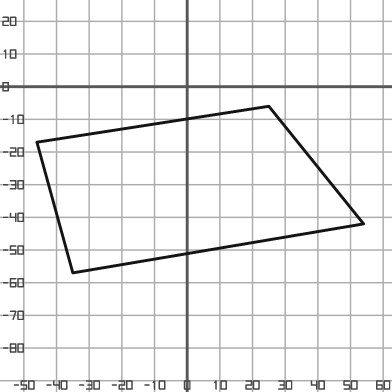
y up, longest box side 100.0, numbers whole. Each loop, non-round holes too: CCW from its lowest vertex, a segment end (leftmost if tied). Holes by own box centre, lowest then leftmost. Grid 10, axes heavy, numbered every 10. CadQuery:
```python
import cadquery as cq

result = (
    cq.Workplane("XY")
    .moveTo(-35.0, -57.0)
    .lineTo(54.0, -42.0)
    .lineTo(25.0, -6.0)
    .lineTo(-46.0, -17.0)
    .close()
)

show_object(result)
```